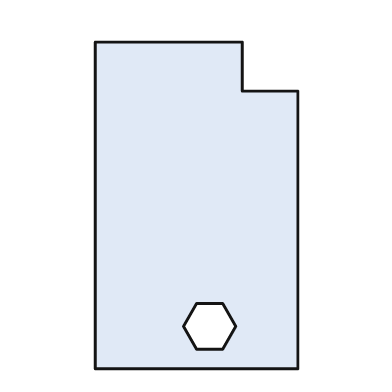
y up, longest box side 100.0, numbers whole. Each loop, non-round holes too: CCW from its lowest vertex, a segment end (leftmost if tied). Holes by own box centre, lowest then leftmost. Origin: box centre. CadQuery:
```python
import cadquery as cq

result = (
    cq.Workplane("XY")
    .moveTo(-31.0, -50.0)
    .lineTo(31.0, -50.0)
    .lineTo(31.0, 35.0)
    .lineTo(14.0, 35.0)
    .lineTo(14.0, 50.0)
    .lineTo(-31.0, 50.0)
    .close()
    .moveTo(0.0, -44.0)
    .lineTo(8.0, -44.0)
    .lineTo(12.0, -37.0)
    .lineTo(8.0, -30.0)
    .lineTo(0.0, -30.0)
    .lineTo(-4.0, -37.0)
    .close()
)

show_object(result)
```